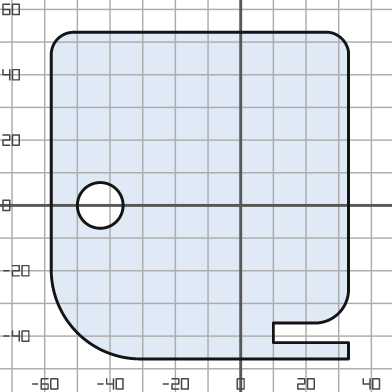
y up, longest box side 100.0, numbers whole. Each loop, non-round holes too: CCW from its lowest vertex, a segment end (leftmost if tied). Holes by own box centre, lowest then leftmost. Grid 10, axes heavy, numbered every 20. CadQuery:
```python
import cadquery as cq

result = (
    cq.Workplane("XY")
    .moveTo(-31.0, -47.0)
    .lineTo(33.0, -47.0)
    .lineTo(33.0, -42.0)
    .lineTo(10.0, -42.0)
    .lineTo(10.0, -36.0)
    .lineTo(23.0, -36.0)
    .threePointArc((30.0, -33.0), (33.0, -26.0))
    .lineTo(33.0, 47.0)
    .threePointArc((31.0, 51.0), (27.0, 53.0))
    .lineTo(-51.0, 53.0)
    .threePointArc((-56.0, 51.0), (-58.0, 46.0))
    .lineTo(-58.0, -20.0)
    .threePointArc((-50.0, -39.0), (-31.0, -47.0))
    .close()
    .moveTo(-43.0, 0.0)
    .circle(7.0)
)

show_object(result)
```